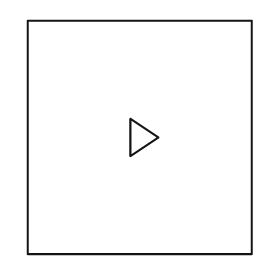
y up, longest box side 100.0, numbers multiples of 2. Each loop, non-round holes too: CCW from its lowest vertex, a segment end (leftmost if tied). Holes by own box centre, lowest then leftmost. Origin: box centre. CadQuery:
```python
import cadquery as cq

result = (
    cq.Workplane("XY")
    .moveTo(-48.0, -50.0)
    .lineTo(48.0, -50.0)
    .lineTo(48.0, 50.0)
    .lineTo(-48.0, 50.0)
    .close()
    .moveTo(-4.0, -8.0)
    .lineTo(8.0, 0.0)
    .lineTo(-4.0, 8.0)
    .close()
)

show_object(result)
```